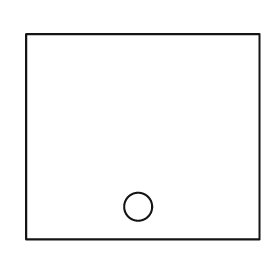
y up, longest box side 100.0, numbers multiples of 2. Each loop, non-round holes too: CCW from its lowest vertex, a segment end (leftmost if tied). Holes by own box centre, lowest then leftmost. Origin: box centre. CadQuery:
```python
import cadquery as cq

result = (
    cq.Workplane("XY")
    .moveTo(-50.0, -44.0)
    .lineTo(50.0, -44.0)
    .lineTo(50.0, 44.0)
    .lineTo(-50.0, 44.0)
    .close()
    .moveTo(-2.0, -30.0)
    .circle(6.0)
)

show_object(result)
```